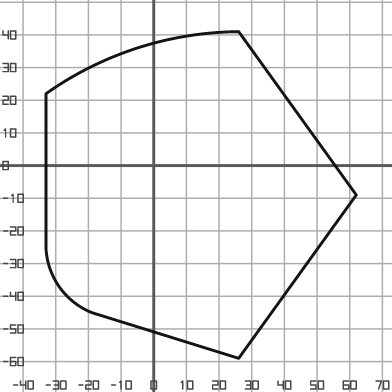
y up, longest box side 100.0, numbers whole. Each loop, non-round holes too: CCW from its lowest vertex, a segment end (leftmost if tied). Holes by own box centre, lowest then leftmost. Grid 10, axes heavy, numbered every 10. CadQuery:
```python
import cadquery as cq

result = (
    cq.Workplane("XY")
    .moveTo(26.0, -59.0)
    .lineTo(62.0, -9.0)
    .lineTo(26.0, 41.0)
    .threePointArc((-5.0, 36.0), (-33.0, 22.0))
    .lineTo(-33.0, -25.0)
    .threePointArc((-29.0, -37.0), (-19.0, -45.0))
    .close()
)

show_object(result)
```